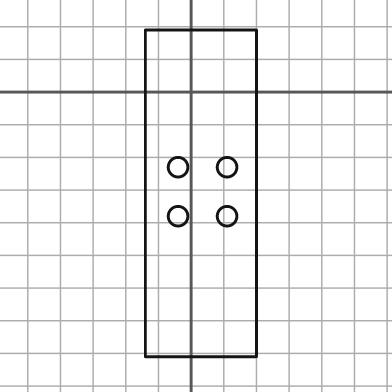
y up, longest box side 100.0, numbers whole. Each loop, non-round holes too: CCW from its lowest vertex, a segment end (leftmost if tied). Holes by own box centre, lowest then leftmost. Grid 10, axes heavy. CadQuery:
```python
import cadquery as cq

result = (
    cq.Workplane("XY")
    .moveTo(-14.0, -81.0)
    .lineTo(20.0, -81.0)
    .lineTo(20.0, 19.0)
    .lineTo(-14.0, 19.0)
    .close()
    .moveTo(-4.0, -38.0)
    .circle(3.0)
    .moveTo(11.0, -38.0)
    .circle(3.0)
    .moveTo(-4.0, -23.0)
    .circle(3.0)
    .moveTo(11.0, -23.0)
    .circle(3.0)
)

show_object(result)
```